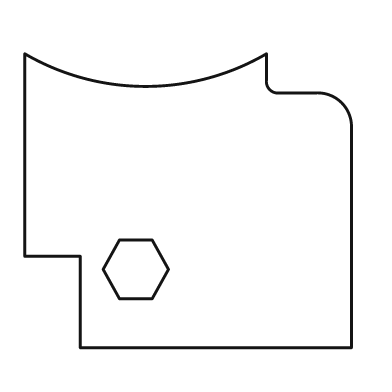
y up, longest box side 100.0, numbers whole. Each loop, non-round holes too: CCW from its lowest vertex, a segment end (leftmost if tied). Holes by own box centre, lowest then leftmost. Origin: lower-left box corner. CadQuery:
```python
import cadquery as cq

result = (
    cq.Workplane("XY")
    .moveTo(17.0, 0.0)
    .lineTo(100.0, 0.0)
    .lineTo(100.0, 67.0)
    .threePointArc((97.0, 75.0), (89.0, 78.0))
    .lineTo(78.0, 78.0)
    .threePointArc((75.0, 79.0), (74.0, 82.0))
    .lineTo(74.0, 90.0)
    .threePointArc((37.0, 80.0), (0.0, 90.0))
    .lineTo(0.0, 28.0)
    .lineTo(17.0, 28.0)
    .close()
    .moveTo(29.0, 15.0)
    .lineTo(39.0, 15.0)
    .lineTo(44.0, 24.0)
    .lineTo(39.0, 33.0)
    .lineTo(29.0, 33.0)
    .lineTo(24.0, 24.0)
    .close()
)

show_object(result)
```